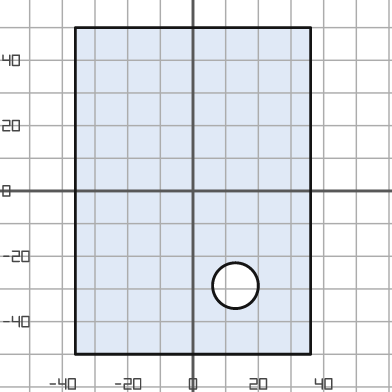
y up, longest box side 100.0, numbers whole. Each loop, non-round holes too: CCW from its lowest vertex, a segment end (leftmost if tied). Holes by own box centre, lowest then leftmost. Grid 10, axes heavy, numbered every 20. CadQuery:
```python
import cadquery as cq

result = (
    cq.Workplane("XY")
    .moveTo(-36.0, -50.0)
    .lineTo(36.0, -50.0)
    .lineTo(36.0, 50.0)
    .lineTo(-36.0, 50.0)
    .close()
    .moveTo(13.0, -29.0)
    .circle(7.0)
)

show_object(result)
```